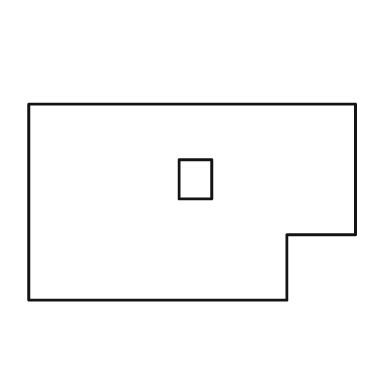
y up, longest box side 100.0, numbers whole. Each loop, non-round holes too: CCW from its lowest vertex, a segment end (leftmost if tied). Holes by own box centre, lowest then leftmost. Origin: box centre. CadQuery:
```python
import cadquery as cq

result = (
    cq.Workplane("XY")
    .moveTo(-50.0, -30.0)
    .lineTo(29.0, -30.0)
    .lineTo(29.0, -10.0)
    .lineTo(50.0, -10.0)
    .lineTo(50.0, 30.0)
    .lineTo(-50.0, 30.0)
    .close()
    .moveTo(-4.0, 1.0)
    .lineTo(6.0, 1.0)
    .lineTo(6.0, 13.0)
    .lineTo(-4.0, 13.0)
    .close()
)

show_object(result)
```